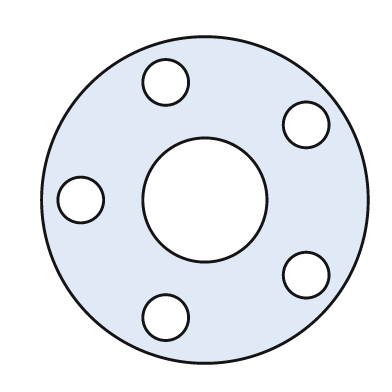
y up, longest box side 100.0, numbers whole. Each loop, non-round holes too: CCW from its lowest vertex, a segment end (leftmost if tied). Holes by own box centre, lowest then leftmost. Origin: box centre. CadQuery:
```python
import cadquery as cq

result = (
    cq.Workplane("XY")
    .moveTo(0.0, 0.0)
    .circle(50.0)
    .moveTo(-12.0, -36.0)
    .circle(7.0)
    .moveTo(31.0, -23.0)
    .circle(7.0)
    .moveTo(-38.0, 0.0)
    .circle(7.0)
    .moveTo(0.0, 0.0)
    .circle(19.0)
    .moveTo(31.0, 23.0)
    .circle(7.0)
    .moveTo(-12.0, 36.0)
    .circle(7.0)
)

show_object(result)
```